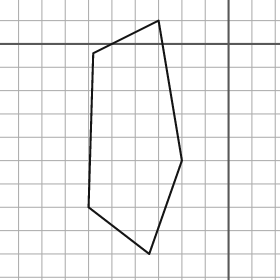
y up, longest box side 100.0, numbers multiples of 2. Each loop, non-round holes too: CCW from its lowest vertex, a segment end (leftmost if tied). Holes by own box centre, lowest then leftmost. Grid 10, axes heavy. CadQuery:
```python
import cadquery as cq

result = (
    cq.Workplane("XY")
    .moveTo(-34.0, -90.0)
    .lineTo(-20.0, -50.0)
    .lineTo(-30.0, 10.0)
    .lineTo(-58.0, -4.0)
    .lineTo(-60.0, -70.0)
    .close()
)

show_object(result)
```